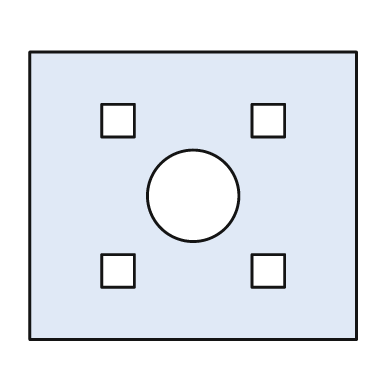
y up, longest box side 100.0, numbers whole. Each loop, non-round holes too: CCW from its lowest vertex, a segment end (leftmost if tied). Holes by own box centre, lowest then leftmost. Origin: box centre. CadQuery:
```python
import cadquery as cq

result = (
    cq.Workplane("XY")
    .moveTo(-50.0, -44.0)
    .lineTo(50.0, -44.0)
    .lineTo(50.0, 44.0)
    .lineTo(-50.0, 44.0)
    .close()
    .moveTo(-28.0, -28.0)
    .lineTo(-18.0, -28.0)
    .lineTo(-18.0, -18.0)
    .lineTo(-28.0, -18.0)
    .close()
    .moveTo(18.0, -28.0)
    .lineTo(28.0, -28.0)
    .lineTo(28.0, -18.0)
    .lineTo(18.0, -18.0)
    .close()
    .moveTo(0.0, 0.0)
    .circle(14.0)
    .moveTo(-28.0, 18.0)
    .lineTo(-18.0, 18.0)
    .lineTo(-18.0, 28.0)
    .lineTo(-28.0, 28.0)
    .close()
    .moveTo(18.0, 18.0)
    .lineTo(28.0, 18.0)
    .lineTo(28.0, 28.0)
    .lineTo(18.0, 28.0)
    .close()
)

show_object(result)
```